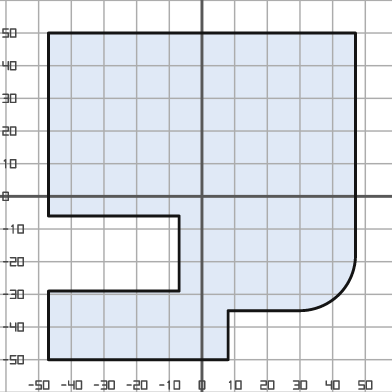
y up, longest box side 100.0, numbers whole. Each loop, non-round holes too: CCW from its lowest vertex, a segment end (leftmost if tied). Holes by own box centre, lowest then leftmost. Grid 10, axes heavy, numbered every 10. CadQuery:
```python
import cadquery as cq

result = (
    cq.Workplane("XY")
    .moveTo(-47.0, -50.0)
    .lineTo(8.0, -50.0)
    .lineTo(8.0, -35.0)
    .lineTo(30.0, -35.0)
    .threePointArc((42.0, -30.0), (47.0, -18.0))
    .lineTo(47.0, 50.0)
    .lineTo(-47.0, 50.0)
    .lineTo(-47.0, -6.0)
    .lineTo(-7.0, -6.0)
    .lineTo(-7.0, -29.0)
    .lineTo(-47.0, -29.0)
    .close()
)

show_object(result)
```